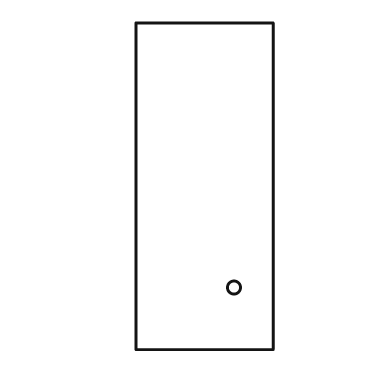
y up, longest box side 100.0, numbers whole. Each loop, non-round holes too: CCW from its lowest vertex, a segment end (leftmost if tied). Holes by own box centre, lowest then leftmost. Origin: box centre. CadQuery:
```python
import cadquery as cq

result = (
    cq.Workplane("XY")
    .moveTo(-21.0, -50.0)
    .lineTo(21.0, -50.0)
    .lineTo(21.0, 50.0)
    .lineTo(-21.0, 50.0)
    .close()
    .moveTo(9.0, -31.0)
    .circle(2.0)
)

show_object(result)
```